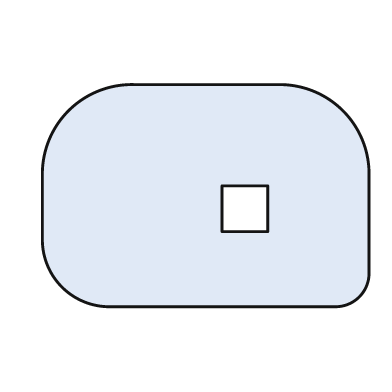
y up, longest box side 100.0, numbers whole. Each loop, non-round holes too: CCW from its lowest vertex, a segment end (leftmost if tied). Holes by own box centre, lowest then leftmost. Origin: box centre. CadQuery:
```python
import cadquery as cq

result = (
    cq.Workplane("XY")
    .moveTo(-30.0, -34.0)
    .lineTo(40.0, -34.0)
    .threePointArc((47.0, -31.0), (50.0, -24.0))
    .lineTo(50.0, 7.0)
    .threePointArc((42.0, 26.0), (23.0, 34.0))
    .lineTo(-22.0, 34.0)
    .threePointArc((-42.0, 26.0), (-50.0, 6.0))
    .lineTo(-50.0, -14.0)
    .threePointArc((-44.0, -28.0), (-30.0, -34.0))
    .close()
    .moveTo(5.0, -11.0)
    .lineTo(19.0, -11.0)
    .lineTo(19.0, 3.0)
    .lineTo(5.0, 3.0)
    .close()
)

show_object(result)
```